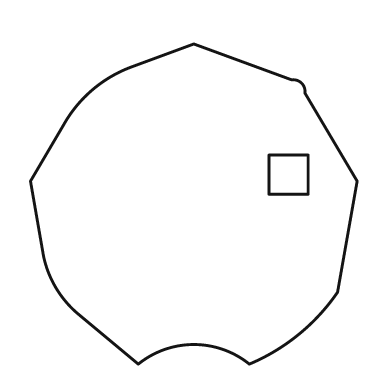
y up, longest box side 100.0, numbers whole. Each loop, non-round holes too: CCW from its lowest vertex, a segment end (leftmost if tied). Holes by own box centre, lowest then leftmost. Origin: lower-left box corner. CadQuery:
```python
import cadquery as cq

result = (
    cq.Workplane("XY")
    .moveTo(33.0, 0.0)
    .threePointArc((50.0, 6.0), (67.0, 0.0))
    .threePointArc((82.0, 9.0), (94.0, 22.0))
    .lineTo(100.0, 56.0)
    .lineTo(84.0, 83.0)
    .threePointArc((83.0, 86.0), (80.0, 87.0))
    .lineTo(50.0, 98.0)
    .lineTo(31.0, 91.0)
    .threePointArc((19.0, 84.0), (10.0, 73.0))
    .lineTo(0.0, 56.0)
    .lineTo(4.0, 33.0)
    .threePointArc((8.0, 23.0), (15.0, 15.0))
    .close()
    .moveTo(73.0, 52.0)
    .lineTo(85.0, 52.0)
    .lineTo(85.0, 64.0)
    .lineTo(73.0, 64.0)
    .close()
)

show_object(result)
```